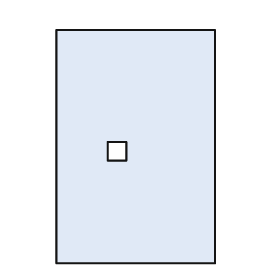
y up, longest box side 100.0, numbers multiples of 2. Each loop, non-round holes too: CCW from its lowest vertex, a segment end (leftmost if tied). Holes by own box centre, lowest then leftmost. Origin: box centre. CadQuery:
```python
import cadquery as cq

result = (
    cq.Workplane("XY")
    .moveTo(-34.0, -50.0)
    .lineTo(34.0, -50.0)
    .lineTo(34.0, 50.0)
    .lineTo(-34.0, 50.0)
    .close()
    .moveTo(-12.0, -6.0)
    .lineTo(-4.0, -6.0)
    .lineTo(-4.0, 2.0)
    .lineTo(-12.0, 2.0)
    .close()
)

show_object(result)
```